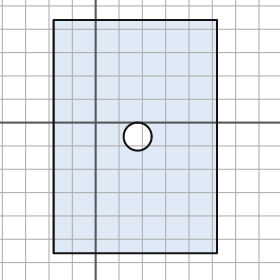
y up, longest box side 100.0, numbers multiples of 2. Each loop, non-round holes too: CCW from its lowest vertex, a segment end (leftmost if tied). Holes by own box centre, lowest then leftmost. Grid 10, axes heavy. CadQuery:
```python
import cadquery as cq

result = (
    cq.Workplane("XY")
    .moveTo(-18.0, -56.0)
    .lineTo(52.0, -56.0)
    .lineTo(52.0, 44.0)
    .lineTo(-18.0, 44.0)
    .close()
    .moveTo(18.0, -6.0)
    .circle(6.0)
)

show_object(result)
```